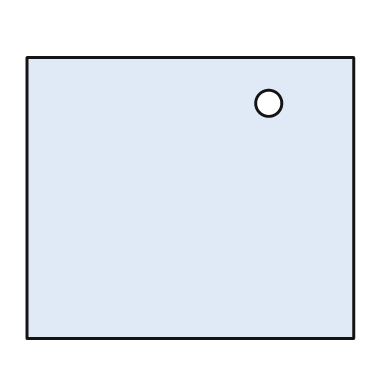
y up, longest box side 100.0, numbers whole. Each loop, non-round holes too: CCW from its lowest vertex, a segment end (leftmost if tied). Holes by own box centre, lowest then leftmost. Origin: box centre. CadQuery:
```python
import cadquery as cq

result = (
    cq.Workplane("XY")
    .moveTo(-50.0, -43.0)
    .lineTo(50.0, -43.0)
    .lineTo(50.0, 43.0)
    .lineTo(-50.0, 43.0)
    .close()
    .moveTo(24.0, 29.0)
    .circle(4.0)
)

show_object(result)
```